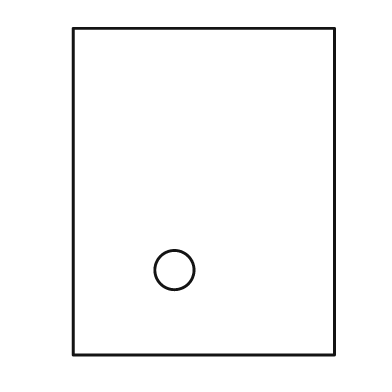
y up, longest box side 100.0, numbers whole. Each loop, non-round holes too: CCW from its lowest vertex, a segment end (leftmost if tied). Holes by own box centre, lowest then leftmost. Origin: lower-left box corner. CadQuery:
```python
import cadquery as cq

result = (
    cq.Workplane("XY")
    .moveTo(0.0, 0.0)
    .lineTo(80.0, 0.0)
    .lineTo(80.0, 100.0)
    .lineTo(0.0, 100.0)
    .close()
    .moveTo(31.0, 26.0)
    .circle(6.0)
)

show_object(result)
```